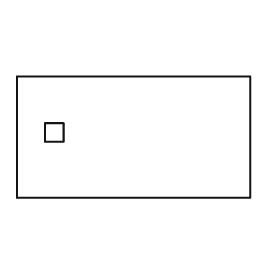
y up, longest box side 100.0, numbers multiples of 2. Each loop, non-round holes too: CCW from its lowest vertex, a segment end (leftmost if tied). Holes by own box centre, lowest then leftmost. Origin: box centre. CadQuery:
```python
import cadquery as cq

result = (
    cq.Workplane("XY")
    .moveTo(-50.0, -26.0)
    .lineTo(50.0, -26.0)
    .lineTo(50.0, 26.0)
    .lineTo(-50.0, 26.0)
    .close()
    .moveTo(-38.0, -2.0)
    .lineTo(-30.0, -2.0)
    .lineTo(-30.0, 6.0)
    .lineTo(-38.0, 6.0)
    .close()
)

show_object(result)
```